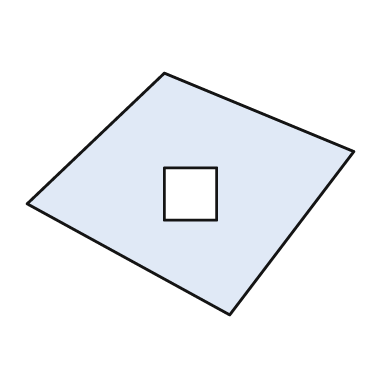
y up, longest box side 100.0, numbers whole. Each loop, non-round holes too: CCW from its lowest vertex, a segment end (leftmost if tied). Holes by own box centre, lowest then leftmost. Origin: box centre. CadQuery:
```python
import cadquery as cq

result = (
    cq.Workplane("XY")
    .moveTo(12.0, -37.0)
    .lineTo(50.0, 13.0)
    .lineTo(-8.0, 37.0)
    .lineTo(-50.0, -3.0)
    .close()
    .moveTo(-8.0, -8.0)
    .lineTo(8.0, -8.0)
    .lineTo(8.0, 8.0)
    .lineTo(-8.0, 8.0)
    .close()
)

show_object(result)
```